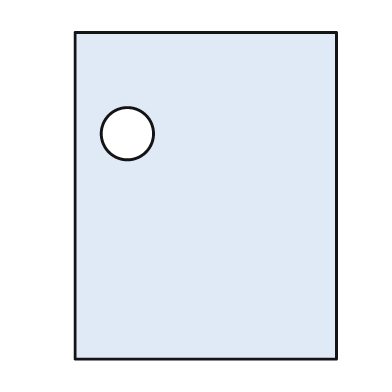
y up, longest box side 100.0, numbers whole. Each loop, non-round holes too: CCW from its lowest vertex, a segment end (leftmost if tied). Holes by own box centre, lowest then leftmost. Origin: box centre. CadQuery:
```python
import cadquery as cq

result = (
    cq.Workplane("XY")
    .moveTo(-40.0, -50.0)
    .lineTo(40.0, -50.0)
    .lineTo(40.0, 50.0)
    .lineTo(-40.0, 50.0)
    .close()
    .moveTo(-24.0, 19.0)
    .circle(8.0)
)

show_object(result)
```